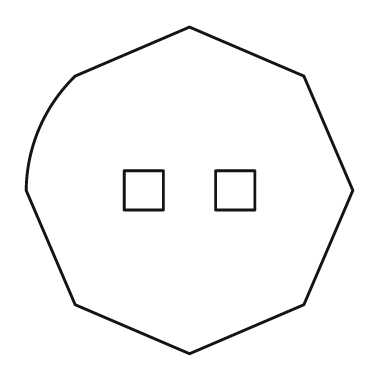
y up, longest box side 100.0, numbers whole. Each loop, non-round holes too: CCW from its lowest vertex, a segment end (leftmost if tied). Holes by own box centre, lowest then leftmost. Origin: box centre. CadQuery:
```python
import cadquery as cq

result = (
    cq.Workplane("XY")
    .moveTo(0.0, -50.0)
    .lineTo(35.0, -35.0)
    .lineTo(50.0, 0.0)
    .lineTo(35.0, 35.0)
    .lineTo(0.0, 50.0)
    .lineTo(-35.0, 35.0)
    .threePointArc((-46.0, 19.0), (-50.0, 0.0))
    .lineTo(-35.0, -35.0)
    .close()
    .moveTo(-20.0, -6.0)
    .lineTo(-8.0, -6.0)
    .lineTo(-8.0, 6.0)
    .lineTo(-20.0, 6.0)
    .close()
    .moveTo(8.0, -6.0)
    .lineTo(20.0, -6.0)
    .lineTo(20.0, 6.0)
    .lineTo(8.0, 6.0)
    .close()
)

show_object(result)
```